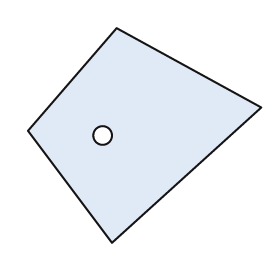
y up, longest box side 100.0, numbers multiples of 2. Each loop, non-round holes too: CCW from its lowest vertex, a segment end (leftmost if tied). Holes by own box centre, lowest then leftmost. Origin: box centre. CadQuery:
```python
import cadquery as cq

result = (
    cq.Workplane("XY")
    .moveTo(-14.0, -46.0)
    .lineTo(50.0, 12.0)
    .lineTo(-12.0, 46.0)
    .lineTo(-50.0, 2.0)
    .close()
    .moveTo(-18.0, 0.0)
    .circle(4.0)
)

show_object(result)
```